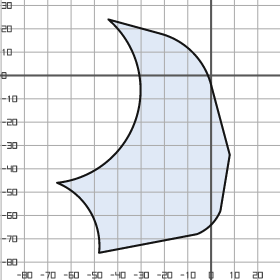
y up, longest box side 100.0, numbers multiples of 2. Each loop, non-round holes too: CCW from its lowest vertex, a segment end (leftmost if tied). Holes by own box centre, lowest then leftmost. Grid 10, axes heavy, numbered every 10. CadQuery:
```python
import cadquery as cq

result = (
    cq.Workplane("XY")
    .moveTo(-48.0, -76.0)
    .lineTo(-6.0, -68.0)
    .threePointArc((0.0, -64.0), (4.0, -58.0))
    .lineTo(8.0, -34.0)
    .lineTo(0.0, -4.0)
    .threePointArc((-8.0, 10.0), (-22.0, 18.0))
    .lineTo(-44.0, 24.0)
    .threePointArc((-32.0, -18.0), (-66.0, -46.0))
    .threePointArc((-52.0, -58.0), (-48.0, -76.0))
    .close()
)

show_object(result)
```